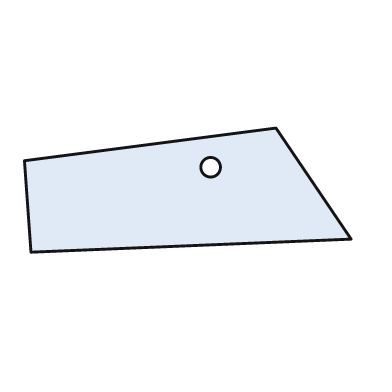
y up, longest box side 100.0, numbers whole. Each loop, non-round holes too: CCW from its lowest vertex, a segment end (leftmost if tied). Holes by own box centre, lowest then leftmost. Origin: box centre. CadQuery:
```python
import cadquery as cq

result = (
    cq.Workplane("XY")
    .moveTo(-48.0, -19.0)
    .lineTo(50.0, -15.0)
    .lineTo(27.0, 19.0)
    .lineTo(-50.0, 9.0)
    .close()
    .moveTo(7.0, 7.0)
    .circle(3.0)
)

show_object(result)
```